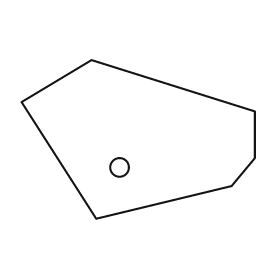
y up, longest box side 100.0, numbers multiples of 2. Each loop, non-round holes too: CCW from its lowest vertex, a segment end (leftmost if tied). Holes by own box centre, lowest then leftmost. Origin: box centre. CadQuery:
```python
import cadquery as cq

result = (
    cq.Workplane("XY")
    .moveTo(-18.0, -34.0)
    .lineTo(40.0, -20.0)
    .lineTo(50.0, -8.0)
    .lineTo(50.0, 12.0)
    .lineTo(-20.0, 34.0)
    .lineTo(-50.0, 16.0)
    .close()
    .moveTo(-8.0, -12.0)
    .circle(4.0)
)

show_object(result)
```